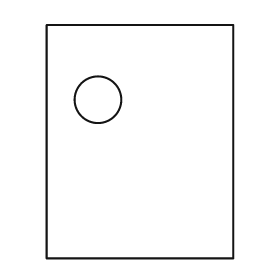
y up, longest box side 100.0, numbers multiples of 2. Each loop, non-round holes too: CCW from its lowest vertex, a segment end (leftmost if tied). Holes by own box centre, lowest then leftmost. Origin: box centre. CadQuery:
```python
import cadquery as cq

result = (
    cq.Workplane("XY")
    .moveTo(-40.0, -50.0)
    .lineTo(40.0, -50.0)
    .lineTo(40.0, 50.0)
    .lineTo(-40.0, 50.0)
    .close()
    .moveTo(-18.0, 18.0)
    .circle(10.0)
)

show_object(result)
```